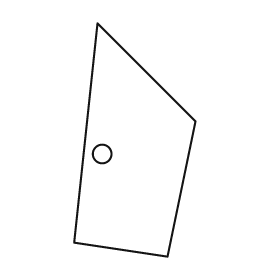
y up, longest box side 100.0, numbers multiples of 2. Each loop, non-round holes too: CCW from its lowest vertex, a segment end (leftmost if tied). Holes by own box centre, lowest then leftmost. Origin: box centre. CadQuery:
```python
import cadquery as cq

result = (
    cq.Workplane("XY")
    .moveTo(14.0, -50.0)
    .lineTo(26.0, 8.0)
    .lineTo(-16.0, 50.0)
    .lineTo(-26.0, -44.0)
    .close()
    .moveTo(-14.0, -6.0)
    .circle(4.0)
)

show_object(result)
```